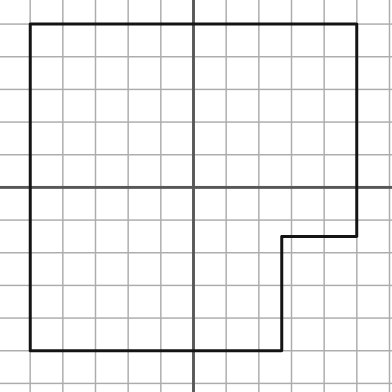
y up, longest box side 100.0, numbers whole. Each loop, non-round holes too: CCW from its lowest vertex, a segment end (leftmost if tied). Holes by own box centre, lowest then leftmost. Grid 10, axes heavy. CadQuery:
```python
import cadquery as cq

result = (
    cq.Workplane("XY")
    .moveTo(-50.0, -50.0)
    .lineTo(27.0, -50.0)
    .lineTo(27.0, -15.0)
    .lineTo(50.0, -15.0)
    .lineTo(50.0, 50.0)
    .lineTo(-50.0, 50.0)
    .close()
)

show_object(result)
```